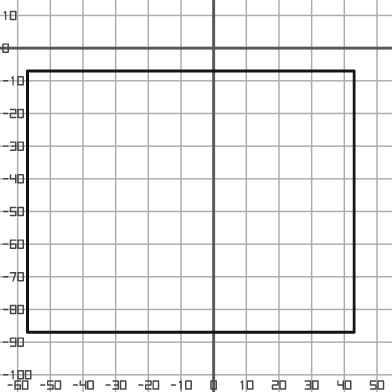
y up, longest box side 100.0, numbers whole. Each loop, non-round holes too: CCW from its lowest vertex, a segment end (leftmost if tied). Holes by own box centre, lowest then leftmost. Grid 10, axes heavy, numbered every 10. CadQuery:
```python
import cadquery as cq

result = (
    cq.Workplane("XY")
    .moveTo(-57.0, -87.0)
    .lineTo(43.0, -87.0)
    .lineTo(43.0, -7.0)
    .lineTo(-57.0, -7.0)
    .close()
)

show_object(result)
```